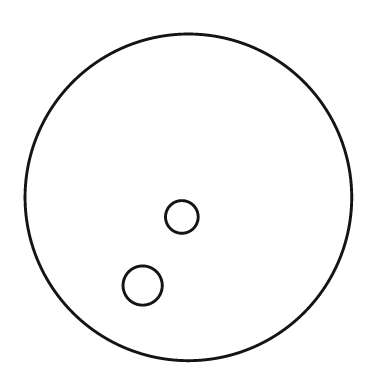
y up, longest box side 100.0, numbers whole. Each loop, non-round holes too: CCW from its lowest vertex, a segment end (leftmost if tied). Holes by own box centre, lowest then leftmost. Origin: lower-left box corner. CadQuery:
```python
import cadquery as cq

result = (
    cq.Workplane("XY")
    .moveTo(50.0, 50.0)
    .circle(50.0)
    .moveTo(36.0, 23.0)
    .circle(6.0)
    .moveTo(48.0, 44.0)
    .circle(5.0)
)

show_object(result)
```